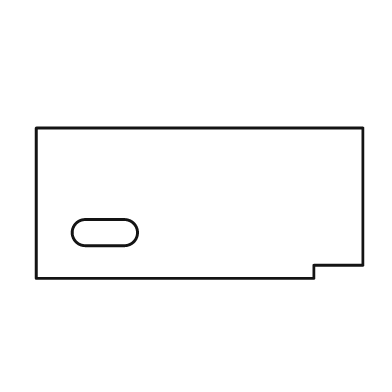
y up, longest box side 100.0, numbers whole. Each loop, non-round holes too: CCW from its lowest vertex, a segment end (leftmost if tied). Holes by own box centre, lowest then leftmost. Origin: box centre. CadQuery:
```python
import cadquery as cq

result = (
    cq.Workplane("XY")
    .moveTo(-50.0, -23.0)
    .lineTo(35.0, -23.0)
    .lineTo(35.0, -19.0)
    .lineTo(50.0, -19.0)
    .lineTo(50.0, 23.0)
    .lineTo(-50.0, 23.0)
    .close()
    .moveTo(-35.0, -13.0)
    .lineTo(-23.0, -13.0)
    .threePointArc((-19.0, -9.0), (-23.0, -5.0))
    .lineTo(-35.0, -5.0)
    .threePointArc((-39.0, -9.0), (-35.0, -13.0))
    .close()
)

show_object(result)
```